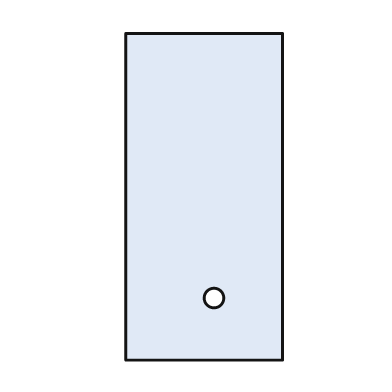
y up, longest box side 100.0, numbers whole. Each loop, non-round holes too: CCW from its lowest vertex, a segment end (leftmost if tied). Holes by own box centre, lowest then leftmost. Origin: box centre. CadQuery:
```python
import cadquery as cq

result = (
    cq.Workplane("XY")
    .moveTo(-24.0, -50.0)
    .lineTo(24.0, -50.0)
    .lineTo(24.0, 50.0)
    .lineTo(-24.0, 50.0)
    .close()
    .moveTo(3.0, -31.0)
    .circle(3.0)
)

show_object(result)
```